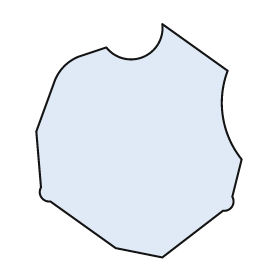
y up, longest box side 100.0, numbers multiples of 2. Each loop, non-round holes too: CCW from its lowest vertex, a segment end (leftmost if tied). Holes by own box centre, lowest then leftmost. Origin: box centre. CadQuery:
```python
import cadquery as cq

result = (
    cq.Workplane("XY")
    .moveTo(10.0, -50.0)
    .lineTo(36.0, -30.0)
    .threePointArc((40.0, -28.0), (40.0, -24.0))
    .lineTo(44.0, -8.0)
    .threePointArc((36.0, 10.0), (38.0, 30.0))
    .lineTo(10.0, 50.0)
    .threePointArc((2.0, 36.0), (-14.0, 40.0))
    .lineTo(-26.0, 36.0)
    .threePointArc((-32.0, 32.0), (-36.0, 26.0))
    .lineTo(-44.0, 4.0)
    .lineTo(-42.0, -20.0)
    .threePointArc((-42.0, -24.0), (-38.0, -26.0))
    .lineTo(-10.0, -46.0)
    .close()
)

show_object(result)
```